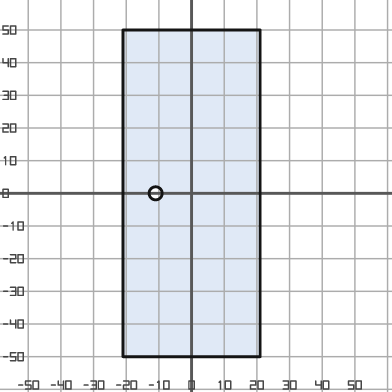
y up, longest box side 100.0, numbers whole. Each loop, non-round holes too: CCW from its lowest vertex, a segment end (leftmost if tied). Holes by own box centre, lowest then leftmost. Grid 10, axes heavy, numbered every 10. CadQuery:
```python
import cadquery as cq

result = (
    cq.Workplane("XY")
    .moveTo(-21.0, -50.0)
    .lineTo(21.0, -50.0)
    .lineTo(21.0, 50.0)
    .lineTo(-21.0, 50.0)
    .close()
    .moveTo(-11.0, 0.0)
    .circle(2.0)
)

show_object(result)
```